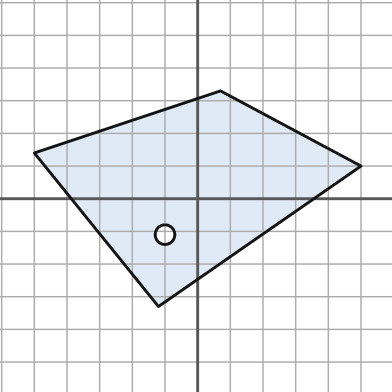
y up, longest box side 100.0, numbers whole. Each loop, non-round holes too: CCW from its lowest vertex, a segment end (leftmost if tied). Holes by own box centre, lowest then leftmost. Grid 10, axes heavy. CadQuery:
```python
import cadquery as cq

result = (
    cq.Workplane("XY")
    .moveTo(-12.0, -33.0)
    .lineTo(50.0, 10.0)
    .lineTo(7.0, 33.0)
    .lineTo(-50.0, 14.0)
    .close()
    .moveTo(-10.0, -11.0)
    .circle(3.0)
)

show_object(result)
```